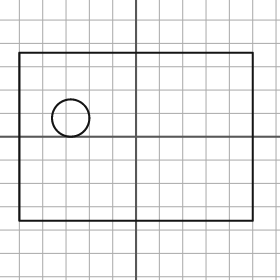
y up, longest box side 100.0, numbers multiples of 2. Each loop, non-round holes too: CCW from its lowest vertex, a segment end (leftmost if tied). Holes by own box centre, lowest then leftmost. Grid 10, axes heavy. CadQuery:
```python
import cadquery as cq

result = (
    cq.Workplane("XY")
    .moveTo(-50.0, -36.0)
    .lineTo(50.0, -36.0)
    .lineTo(50.0, 36.0)
    .lineTo(-50.0, 36.0)
    .close()
    .moveTo(-28.0, 8.0)
    .circle(8.0)
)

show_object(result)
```